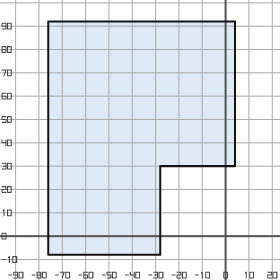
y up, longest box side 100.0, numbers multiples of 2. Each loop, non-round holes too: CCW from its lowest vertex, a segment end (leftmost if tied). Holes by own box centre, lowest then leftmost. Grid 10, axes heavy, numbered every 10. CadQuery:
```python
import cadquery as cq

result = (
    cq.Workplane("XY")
    .moveTo(-76.0, -8.0)
    .lineTo(-28.0, -8.0)
    .lineTo(-28.0, 30.0)
    .lineTo(4.0, 30.0)
    .lineTo(4.0, 92.0)
    .lineTo(-76.0, 92.0)
    .close()
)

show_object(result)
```